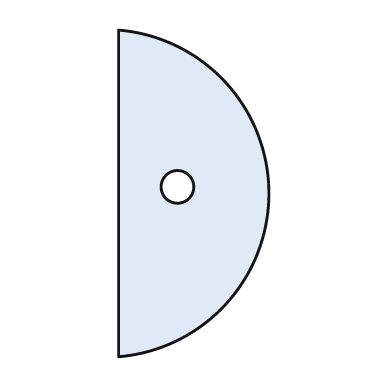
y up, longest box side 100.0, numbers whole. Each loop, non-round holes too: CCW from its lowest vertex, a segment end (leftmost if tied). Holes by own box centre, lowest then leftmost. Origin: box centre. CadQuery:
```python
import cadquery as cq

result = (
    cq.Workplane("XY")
    .moveTo(-23.0, -50.0)
    .threePointArc((23.0, 0.0), (-23.0, 50.0))
    .close()
    .moveTo(-5.0, 2.0)
    .circle(5.0)
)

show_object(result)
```